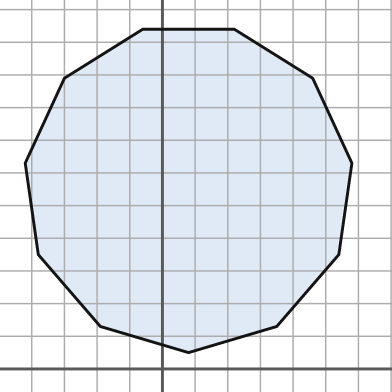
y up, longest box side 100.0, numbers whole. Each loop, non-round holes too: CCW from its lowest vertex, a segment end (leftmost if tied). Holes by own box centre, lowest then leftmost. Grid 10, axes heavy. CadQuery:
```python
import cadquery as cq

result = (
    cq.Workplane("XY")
    .moveTo(8.0, 5.0)
    .lineTo(35.0, 13.0)
    .lineTo(54.0, 35.0)
    .lineTo(58.0, 63.0)
    .lineTo(46.0, 89.0)
    .lineTo(22.0, 104.0)
    .lineTo(-6.0, 104.0)
    .lineTo(-30.0, 89.0)
    .lineTo(-42.0, 63.0)
    .lineTo(-38.0, 35.0)
    .lineTo(-19.0, 13.0)
    .close()
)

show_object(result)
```